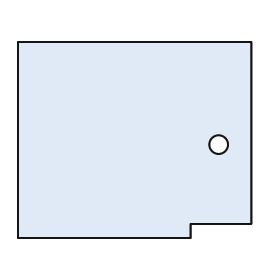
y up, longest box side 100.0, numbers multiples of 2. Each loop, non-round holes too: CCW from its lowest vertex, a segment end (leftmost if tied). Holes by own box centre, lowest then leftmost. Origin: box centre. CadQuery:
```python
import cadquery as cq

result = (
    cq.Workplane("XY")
    .moveTo(-50.0, -42.0)
    .lineTo(24.0, -42.0)
    .lineTo(24.0, -36.0)
    .lineTo(50.0, -36.0)
    .lineTo(50.0, 42.0)
    .lineTo(-50.0, 42.0)
    .close()
    .moveTo(36.0, -2.0)
    .circle(4.0)
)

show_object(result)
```